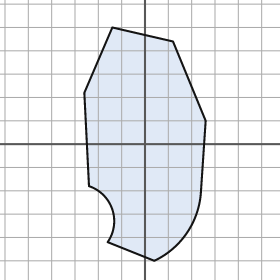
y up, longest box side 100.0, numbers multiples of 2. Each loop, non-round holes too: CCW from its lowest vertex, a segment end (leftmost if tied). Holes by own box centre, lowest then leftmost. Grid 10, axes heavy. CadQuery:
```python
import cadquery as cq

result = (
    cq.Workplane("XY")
    .moveTo(4.0, -50.0)
    .threePointArc((18.0, -38.0), (24.0, -20.0))
    .lineTo(26.0, 10.0)
    .lineTo(12.0, 44.0)
    .lineTo(-14.0, 50.0)
    .lineTo(-26.0, 22.0)
    .lineTo(-24.0, -18.0)
    .threePointArc((-14.0, -28.0), (-16.0, -42.0))
    .close()
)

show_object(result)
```